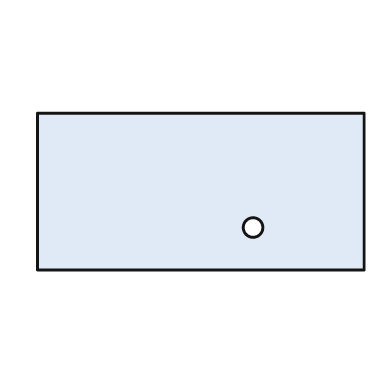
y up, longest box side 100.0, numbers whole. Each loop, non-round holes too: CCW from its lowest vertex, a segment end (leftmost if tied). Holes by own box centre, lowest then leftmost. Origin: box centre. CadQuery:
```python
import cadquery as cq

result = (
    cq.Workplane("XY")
    .moveTo(-50.0, -24.0)
    .lineTo(50.0, -24.0)
    .lineTo(50.0, 24.0)
    .lineTo(-50.0, 24.0)
    .close()
    .moveTo(16.0, -11.0)
    .circle(3.0)
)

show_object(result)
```